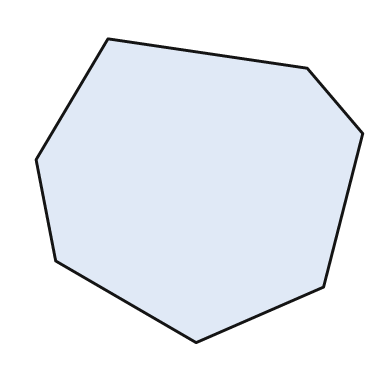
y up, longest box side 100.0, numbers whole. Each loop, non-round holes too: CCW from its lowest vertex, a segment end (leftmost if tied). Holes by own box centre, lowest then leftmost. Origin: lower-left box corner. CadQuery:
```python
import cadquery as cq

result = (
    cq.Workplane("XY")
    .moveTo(49.0, 0.0)
    .lineTo(88.0, 17.0)
    .lineTo(100.0, 64.0)
    .lineTo(83.0, 84.0)
    .lineTo(22.0, 93.0)
    .lineTo(0.0, 56.0)
    .lineTo(6.0, 25.0)
    .close()
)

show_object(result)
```